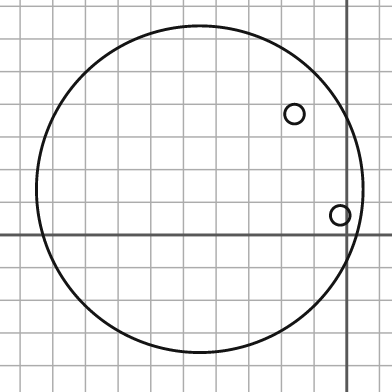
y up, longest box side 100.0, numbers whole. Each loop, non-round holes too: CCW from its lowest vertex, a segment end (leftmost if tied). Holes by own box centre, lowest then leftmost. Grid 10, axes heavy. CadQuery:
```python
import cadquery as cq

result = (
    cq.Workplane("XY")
    .moveTo(-45.0, 14.0)
    .circle(50.0)
    .moveTo(-2.0, 6.0)
    .circle(3.0)
    .moveTo(-16.0, 37.0)
    .circle(3.0)
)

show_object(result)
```